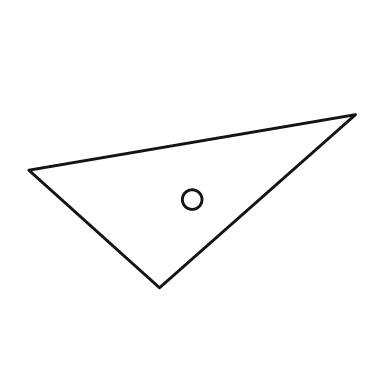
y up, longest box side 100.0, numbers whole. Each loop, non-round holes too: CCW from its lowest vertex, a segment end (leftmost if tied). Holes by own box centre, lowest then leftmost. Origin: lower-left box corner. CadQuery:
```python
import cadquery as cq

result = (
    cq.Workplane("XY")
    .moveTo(40.0, 0.0)
    .lineTo(100.0, 53.0)
    .lineTo(0.0, 36.0)
    .close()
    .moveTo(50.0, 27.0)
    .circle(3.0)
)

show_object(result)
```